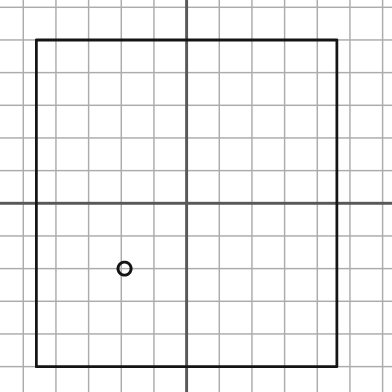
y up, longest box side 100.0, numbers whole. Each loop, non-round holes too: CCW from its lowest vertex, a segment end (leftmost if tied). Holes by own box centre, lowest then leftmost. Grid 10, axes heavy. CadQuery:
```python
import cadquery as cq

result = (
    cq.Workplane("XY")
    .moveTo(-46.0, -50.0)
    .lineTo(46.0, -50.0)
    .lineTo(46.0, 50.0)
    .lineTo(-46.0, 50.0)
    .close()
    .moveTo(-19.0, -20.0)
    .circle(2.0)
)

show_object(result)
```